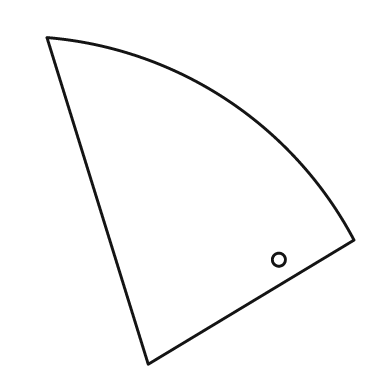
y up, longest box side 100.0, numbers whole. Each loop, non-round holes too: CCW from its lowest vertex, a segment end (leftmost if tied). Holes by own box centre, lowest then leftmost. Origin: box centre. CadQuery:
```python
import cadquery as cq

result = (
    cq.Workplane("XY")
    .moveTo(-16.0, -50.0)
    .lineTo(47.0, -12.0)
    .threePointArc((8.0, 31.0), (-47.0, 50.0))
    .close()
    .moveTo(24.0, -18.0)
    .circle(2.0)
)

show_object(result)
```